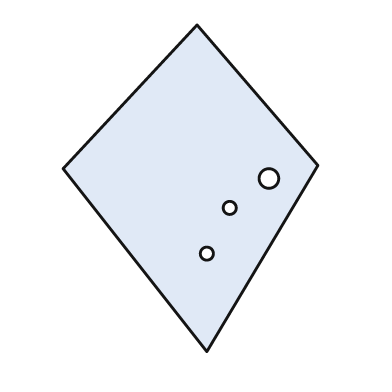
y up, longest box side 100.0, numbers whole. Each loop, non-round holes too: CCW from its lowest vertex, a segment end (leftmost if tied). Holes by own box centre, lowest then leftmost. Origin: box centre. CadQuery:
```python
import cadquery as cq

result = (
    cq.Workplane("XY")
    .moveTo(5.0, -50.0)
    .lineTo(39.0, 7.0)
    .lineTo(2.0, 50.0)
    .lineTo(-39.0, 6.0)
    .close()
    .moveTo(5.0, -20.0)
    .circle(2.0)
    .moveTo(12.0, -6.0)
    .circle(2.0)
    .moveTo(24.0, 3.0)
    .circle(3.0)
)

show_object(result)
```